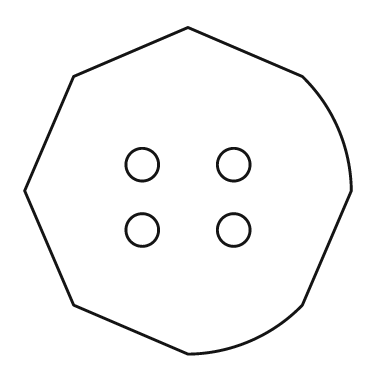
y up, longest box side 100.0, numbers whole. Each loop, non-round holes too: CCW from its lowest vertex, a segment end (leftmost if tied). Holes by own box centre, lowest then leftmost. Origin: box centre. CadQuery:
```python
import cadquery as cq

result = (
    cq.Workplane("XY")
    .moveTo(0.0, -50.0)
    .threePointArc((19.0, -46.0), (35.0, -35.0))
    .lineTo(50.0, 0.0)
    .threePointArc((46.0, 19.0), (35.0, 35.0))
    .lineTo(0.0, 50.0)
    .lineTo(-35.0, 35.0)
    .lineTo(-50.0, 0.0)
    .lineTo(-35.0, -35.0)
    .close()
    .moveTo(-14.0, -12.0)
    .circle(5.0)
    .moveTo(14.0, -12.0)
    .circle(5.0)
    .moveTo(-14.0, 8.0)
    .circle(5.0)
    .moveTo(14.0, 8.0)
    .circle(5.0)
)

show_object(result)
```